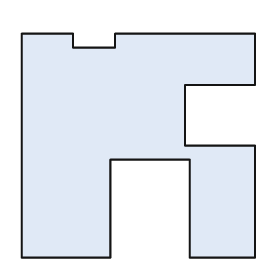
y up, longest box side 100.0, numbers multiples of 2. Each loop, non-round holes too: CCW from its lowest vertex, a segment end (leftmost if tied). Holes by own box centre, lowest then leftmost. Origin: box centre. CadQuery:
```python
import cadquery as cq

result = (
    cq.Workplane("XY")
    .moveTo(-50.0, -48.0)
    .lineTo(-12.0, -48.0)
    .lineTo(-12.0, -6.0)
    .lineTo(22.0, -6.0)
    .lineTo(22.0, -48.0)
    .lineTo(50.0, -48.0)
    .lineTo(50.0, 0.0)
    .lineTo(20.0, 0.0)
    .lineTo(20.0, 26.0)
    .lineTo(50.0, 26.0)
    .lineTo(50.0, 48.0)
    .lineTo(-10.0, 48.0)
    .lineTo(-10.0, 42.0)
    .lineTo(-28.0, 42.0)
    .lineTo(-28.0, 48.0)
    .lineTo(-50.0, 48.0)
    .close()
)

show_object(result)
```